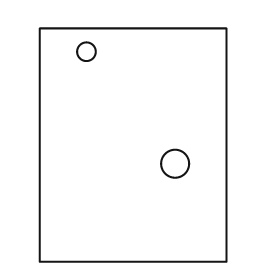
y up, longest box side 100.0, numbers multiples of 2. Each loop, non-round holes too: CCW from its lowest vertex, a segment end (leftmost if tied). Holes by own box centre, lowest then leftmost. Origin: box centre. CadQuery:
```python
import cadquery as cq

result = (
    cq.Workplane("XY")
    .moveTo(-40.0, -50.0)
    .lineTo(40.0, -50.0)
    .lineTo(40.0, 50.0)
    .lineTo(-40.0, 50.0)
    .close()
    .moveTo(18.0, -8.0)
    .circle(6.0)
    .moveTo(-20.0, 40.0)
    .circle(4.0)
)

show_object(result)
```